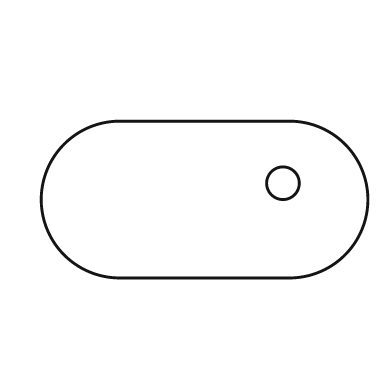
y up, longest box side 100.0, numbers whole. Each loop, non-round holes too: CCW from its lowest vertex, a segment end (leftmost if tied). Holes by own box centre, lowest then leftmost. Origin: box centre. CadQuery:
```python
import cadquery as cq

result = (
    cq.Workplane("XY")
    .moveTo(-26.0, -24.0)
    .lineTo(26.0, -24.0)
    .threePointArc((50.0, 0.0), (26.0, 24.0))
    .lineTo(-26.0, 24.0)
    .threePointArc((-50.0, 0.0), (-26.0, -24.0))
    .close()
    .moveTo(24.0, 5.0)
    .circle(5.0)
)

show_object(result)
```